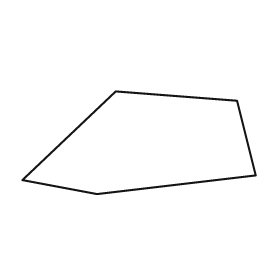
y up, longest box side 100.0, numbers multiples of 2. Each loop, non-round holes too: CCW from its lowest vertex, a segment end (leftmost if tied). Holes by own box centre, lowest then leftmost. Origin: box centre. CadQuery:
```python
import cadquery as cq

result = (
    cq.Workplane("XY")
    .moveTo(-18.0, -22.0)
    .lineTo(50.0, -14.0)
    .lineTo(42.0, 18.0)
    .lineTo(-10.0, 22.0)
    .lineTo(-50.0, -16.0)
    .close()
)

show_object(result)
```